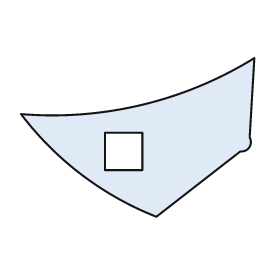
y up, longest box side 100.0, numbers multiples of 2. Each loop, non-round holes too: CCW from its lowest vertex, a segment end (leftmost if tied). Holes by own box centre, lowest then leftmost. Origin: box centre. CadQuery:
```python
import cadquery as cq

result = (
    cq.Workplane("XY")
    .moveTo(8.0, -34.0)
    .lineTo(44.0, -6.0)
    .threePointArc((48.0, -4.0), (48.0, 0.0))
    .lineTo(50.0, 34.0)
    .threePointArc((2.0, 14.0), (-50.0, 10.0))
    .threePointArc((-24.0, -16.0), (8.0, -34.0))
    .close()
    .moveTo(-14.0, -14.0)
    .lineTo(2.0, -14.0)
    .lineTo(2.0, 2.0)
    .lineTo(-14.0, 2.0)
    .close()
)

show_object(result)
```